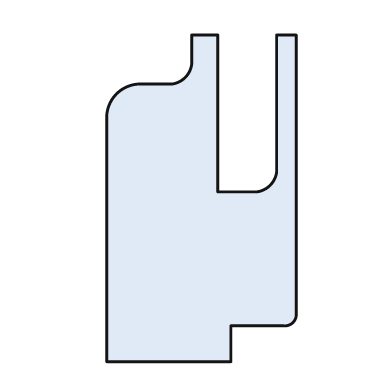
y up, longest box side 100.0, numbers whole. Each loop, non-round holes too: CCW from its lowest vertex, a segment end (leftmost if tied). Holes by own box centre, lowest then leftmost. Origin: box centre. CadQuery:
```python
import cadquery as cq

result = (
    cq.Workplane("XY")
    .moveTo(-29.0, -50.0)
    .lineTo(9.0, -50.0)
    .lineTo(9.0, -39.0)
    .lineTo(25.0, -39.0)
    .threePointArc((28.0, -38.0), (29.0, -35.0))
    .lineTo(29.0, 50.0)
    .lineTo(23.0, 50.0)
    .lineTo(23.0, 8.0)
    .threePointArc((21.0, 4.0), (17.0, 2.0))
    .lineTo(5.0, 2.0)
    .lineTo(5.0, 50.0)
    .lineTo(-3.0, 50.0)
    .lineTo(-3.0, 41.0)
    .threePointArc((-5.0, 37.0), (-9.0, 35.0))
    .lineTo(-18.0, 35.0)
    .threePointArc((-26.0, 32.0), (-29.0, 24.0))
    .close()
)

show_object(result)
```